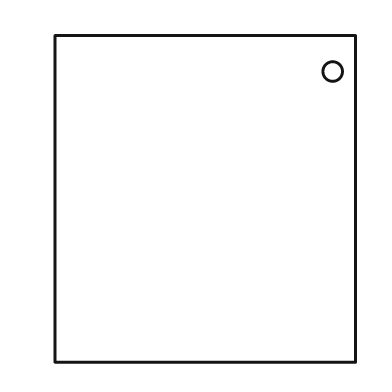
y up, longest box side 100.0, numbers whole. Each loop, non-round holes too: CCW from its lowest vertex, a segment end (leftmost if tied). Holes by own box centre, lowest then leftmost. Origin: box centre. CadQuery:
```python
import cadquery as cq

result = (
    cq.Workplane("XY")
    .moveTo(-46.0, -50.0)
    .lineTo(46.0, -50.0)
    .lineTo(46.0, 50.0)
    .lineTo(-46.0, 50.0)
    .close()
    .moveTo(39.0, 39.0)
    .circle(3.0)
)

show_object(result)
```